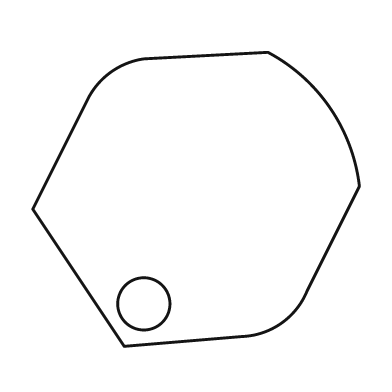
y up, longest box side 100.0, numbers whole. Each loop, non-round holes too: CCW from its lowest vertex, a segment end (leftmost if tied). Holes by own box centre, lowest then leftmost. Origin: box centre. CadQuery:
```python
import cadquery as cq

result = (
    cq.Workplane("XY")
    .moveTo(-22.0, -45.0)
    .lineTo(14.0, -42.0)
    .threePointArc((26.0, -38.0), (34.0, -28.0))
    .lineTo(50.0, 4.0)
    .threePointArc((41.0, 28.0), (22.0, 45.0))
    .lineTo(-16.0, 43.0)
    .threePointArc((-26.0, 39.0), (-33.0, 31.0))
    .lineTo(-50.0, -3.0)
    .close()
    .moveTo(-16.0, -32.0)
    .circle(8.0)
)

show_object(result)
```